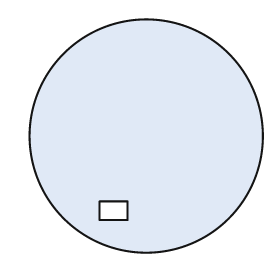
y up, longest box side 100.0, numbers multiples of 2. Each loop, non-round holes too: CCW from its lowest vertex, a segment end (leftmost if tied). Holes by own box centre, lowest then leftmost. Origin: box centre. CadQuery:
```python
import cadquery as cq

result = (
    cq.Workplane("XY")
    .moveTo(0.0, 0.0)
    .circle(50.0)
    .moveTo(-20.0, -36.0)
    .lineTo(-8.0, -36.0)
    .lineTo(-8.0, -28.0)
    .lineTo(-20.0, -28.0)
    .close()
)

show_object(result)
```